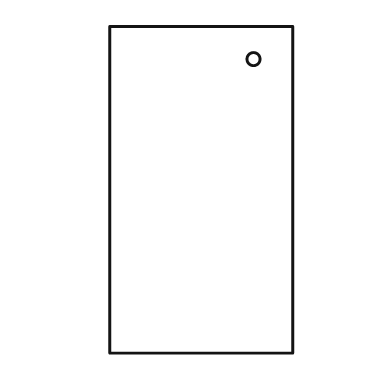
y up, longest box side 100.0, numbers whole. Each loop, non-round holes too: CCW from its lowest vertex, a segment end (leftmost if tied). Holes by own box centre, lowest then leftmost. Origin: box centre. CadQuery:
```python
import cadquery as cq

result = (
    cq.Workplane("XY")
    .moveTo(-28.0, -50.0)
    .lineTo(28.0, -50.0)
    .lineTo(28.0, 50.0)
    .lineTo(-28.0, 50.0)
    .close()
    .moveTo(16.0, 40.0)
    .circle(2.0)
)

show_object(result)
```